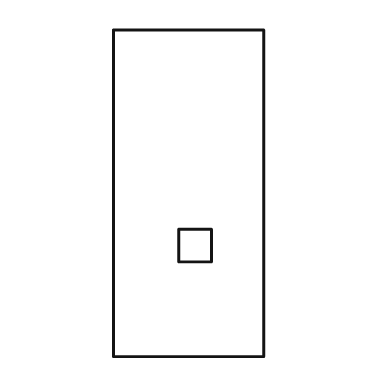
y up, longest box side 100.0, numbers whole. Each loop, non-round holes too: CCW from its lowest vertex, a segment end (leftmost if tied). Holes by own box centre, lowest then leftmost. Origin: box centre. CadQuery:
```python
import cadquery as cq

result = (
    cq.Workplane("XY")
    .moveTo(-23.0, -50.0)
    .lineTo(23.0, -50.0)
    .lineTo(23.0, 50.0)
    .lineTo(-23.0, 50.0)
    .close()
    .moveTo(-3.0, -21.0)
    .lineTo(7.0, -21.0)
    .lineTo(7.0, -11.0)
    .lineTo(-3.0, -11.0)
    .close()
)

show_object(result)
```